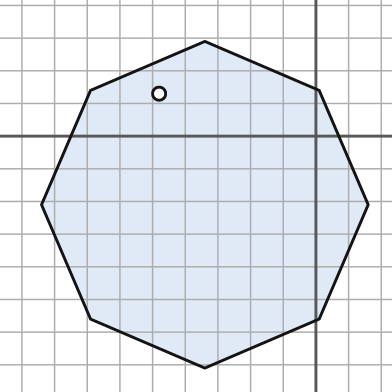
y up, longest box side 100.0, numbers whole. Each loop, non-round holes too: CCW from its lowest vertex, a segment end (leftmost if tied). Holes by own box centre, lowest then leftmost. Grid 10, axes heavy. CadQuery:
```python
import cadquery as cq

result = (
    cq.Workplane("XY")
    .moveTo(-34.0, -71.0)
    .lineTo(1.0, -56.0)
    .lineTo(16.0, -21.0)
    .lineTo(1.0, 14.0)
    .lineTo(-34.0, 29.0)
    .lineTo(-69.0, 14.0)
    .lineTo(-84.0, -21.0)
    .lineTo(-69.0, -56.0)
    .close()
    .moveTo(-48.0, 13.0)
    .circle(2.0)
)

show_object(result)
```